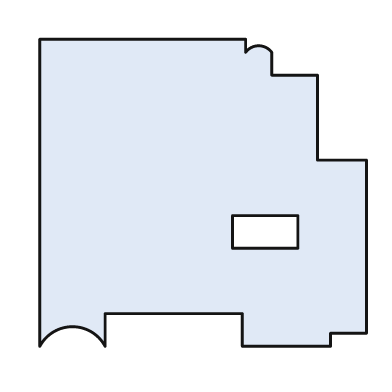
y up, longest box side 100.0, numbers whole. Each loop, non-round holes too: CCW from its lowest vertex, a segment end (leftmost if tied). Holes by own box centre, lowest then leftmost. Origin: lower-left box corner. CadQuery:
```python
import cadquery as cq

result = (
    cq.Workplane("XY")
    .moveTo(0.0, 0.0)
    .threePointArc((10.0, 6.0), (20.0, 0.0))
    .lineTo(20.0, 10.0)
    .lineTo(62.0, 10.0)
    .lineTo(62.0, 0.0)
    .lineTo(89.0, 0.0)
    .lineTo(89.0, 4.0)
    .lineTo(100.0, 4.0)
    .lineTo(100.0, 57.0)
    .lineTo(85.0, 57.0)
    .lineTo(85.0, 83.0)
    .lineTo(71.0, 83.0)
    .lineTo(71.0, 90.0)
    .threePointArc((67.0, 92.0), (63.0, 90.0))
    .lineTo(63.0, 94.0)
    .lineTo(0.0, 94.0)
    .close()
    .moveTo(59.0, 30.0)
    .lineTo(79.0, 30.0)
    .lineTo(79.0, 40.0)
    .lineTo(59.0, 40.0)
    .close()
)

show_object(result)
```